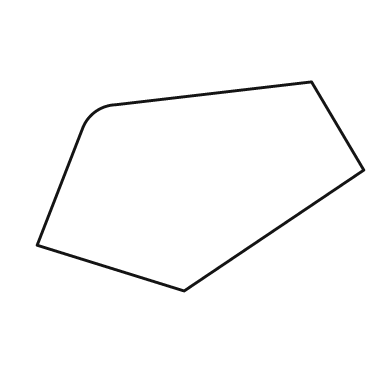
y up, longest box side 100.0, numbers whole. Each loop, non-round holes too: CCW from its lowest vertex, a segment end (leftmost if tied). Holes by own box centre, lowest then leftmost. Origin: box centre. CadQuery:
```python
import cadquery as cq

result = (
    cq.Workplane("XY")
    .moveTo(-5.0, -32.0)
    .lineTo(50.0, 5.0)
    .lineTo(34.0, 32.0)
    .lineTo(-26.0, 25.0)
    .threePointArc((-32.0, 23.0), (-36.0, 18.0))
    .lineTo(-50.0, -18.0)
    .close()
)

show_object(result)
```